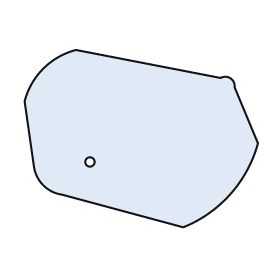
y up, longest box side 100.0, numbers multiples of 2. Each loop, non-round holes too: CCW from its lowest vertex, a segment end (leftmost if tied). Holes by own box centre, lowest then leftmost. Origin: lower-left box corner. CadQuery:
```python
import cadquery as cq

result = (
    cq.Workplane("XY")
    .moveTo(68.0, 0.0)
    .threePointArc((88.0, 14.0), (100.0, 36.0))
    .lineTo(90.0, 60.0)
    .threePointArc((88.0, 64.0), (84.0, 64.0))
    .lineTo(22.0, 76.0)
    .threePointArc((8.0, 68.0), (0.0, 54.0))
    .lineTo(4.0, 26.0)
    .threePointArc((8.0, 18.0), (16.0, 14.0))
    .close()
    .moveTo(28.0, 28.0)
    .circle(2.0)
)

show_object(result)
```